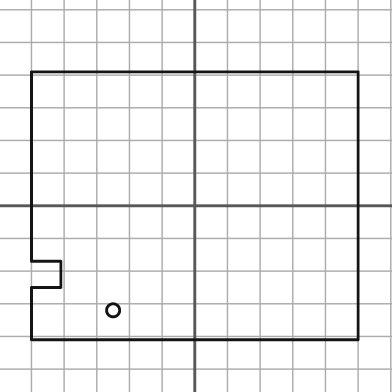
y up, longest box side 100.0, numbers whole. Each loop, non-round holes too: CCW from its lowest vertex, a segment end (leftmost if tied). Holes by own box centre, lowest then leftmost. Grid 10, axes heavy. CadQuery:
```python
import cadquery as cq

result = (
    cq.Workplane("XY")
    .moveTo(-50.0, -41.0)
    .lineTo(50.0, -41.0)
    .lineTo(50.0, 41.0)
    .lineTo(-50.0, 41.0)
    .lineTo(-50.0, -17.0)
    .lineTo(-41.0, -17.0)
    .lineTo(-41.0, -25.0)
    .lineTo(-50.0, -25.0)
    .close()
    .moveTo(-25.0, -32.0)
    .circle(2.0)
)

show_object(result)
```